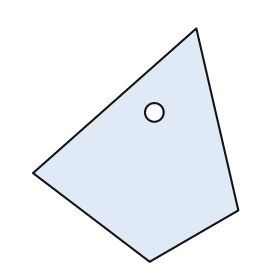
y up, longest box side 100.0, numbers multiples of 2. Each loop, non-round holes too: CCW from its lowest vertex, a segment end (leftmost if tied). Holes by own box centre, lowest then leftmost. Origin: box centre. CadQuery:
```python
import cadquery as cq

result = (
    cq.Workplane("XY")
    .moveTo(6.0, -50.0)
    .lineTo(44.0, -28.0)
    .lineTo(26.0, 50.0)
    .lineTo(-44.0, -12.0)
    .close()
    .moveTo(8.0, 14.0)
    .circle(4.0)
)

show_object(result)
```